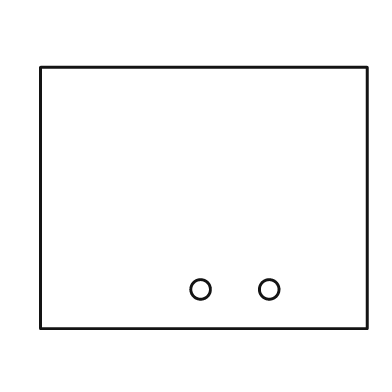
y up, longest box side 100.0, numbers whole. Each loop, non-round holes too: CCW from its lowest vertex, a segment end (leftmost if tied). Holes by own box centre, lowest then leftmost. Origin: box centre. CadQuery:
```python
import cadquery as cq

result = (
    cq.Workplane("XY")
    .moveTo(-50.0, -40.0)
    .lineTo(50.0, -40.0)
    .lineTo(50.0, 40.0)
    .lineTo(-50.0, 40.0)
    .close()
    .moveTo(-1.0, -28.0)
    .circle(3.0)
    .moveTo(20.0, -28.0)
    .circle(3.0)
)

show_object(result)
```